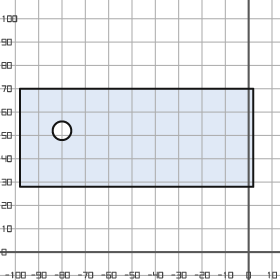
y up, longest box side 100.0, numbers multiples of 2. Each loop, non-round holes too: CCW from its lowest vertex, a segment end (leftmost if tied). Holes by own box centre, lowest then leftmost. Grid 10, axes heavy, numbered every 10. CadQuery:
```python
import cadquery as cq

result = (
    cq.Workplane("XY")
    .moveTo(-98.0, 28.0)
    .lineTo(2.0, 28.0)
    .lineTo(2.0, 70.0)
    .lineTo(-98.0, 70.0)
    .close()
    .moveTo(-80.0, 52.0)
    .circle(4.0)
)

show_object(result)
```